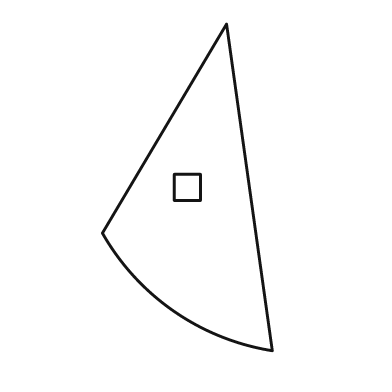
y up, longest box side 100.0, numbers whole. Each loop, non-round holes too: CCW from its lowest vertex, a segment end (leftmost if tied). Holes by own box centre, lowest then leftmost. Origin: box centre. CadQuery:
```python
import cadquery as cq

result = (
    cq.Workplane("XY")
    .moveTo(26.0, -50.0)
    .lineTo(12.0, 50.0)
    .lineTo(-26.0, -14.0)
    .threePointArc((-4.0, -38.0), (26.0, -50.0))
    .close()
    .moveTo(-4.0, -4.0)
    .lineTo(4.0, -4.0)
    .lineTo(4.0, 4.0)
    .lineTo(-4.0, 4.0)
    .close()
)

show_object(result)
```